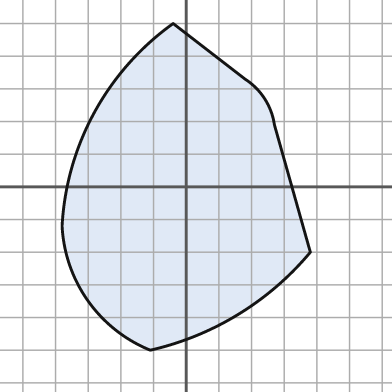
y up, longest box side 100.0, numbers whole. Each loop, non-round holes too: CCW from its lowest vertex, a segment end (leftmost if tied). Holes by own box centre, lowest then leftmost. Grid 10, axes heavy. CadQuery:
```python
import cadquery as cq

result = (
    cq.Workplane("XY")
    .moveTo(-11.0, -50.0)
    .threePointArc((16.0, -39.0), (38.0, -20.0))
    .lineTo(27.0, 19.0)
    .threePointArc((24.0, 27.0), (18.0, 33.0))
    .lineTo(-4.0, 50.0)
    .threePointArc((-28.0, 23.0), (-38.0, -12.0))
    .threePointArc((-30.0, -35.0), (-11.0, -50.0))
    .close()
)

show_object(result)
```